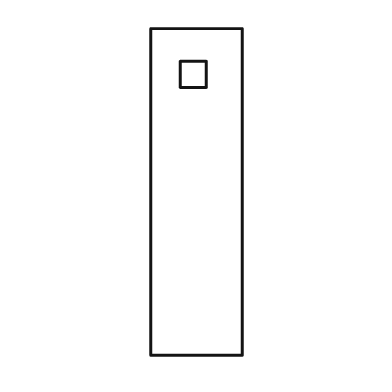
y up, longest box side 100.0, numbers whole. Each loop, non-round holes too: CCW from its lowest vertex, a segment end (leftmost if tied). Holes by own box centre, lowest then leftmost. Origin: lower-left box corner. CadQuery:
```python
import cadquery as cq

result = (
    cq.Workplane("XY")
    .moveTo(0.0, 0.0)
    .lineTo(28.0, 0.0)
    .lineTo(28.0, 100.0)
    .lineTo(0.0, 100.0)
    .close()
    .moveTo(9.0, 82.0)
    .lineTo(17.0, 82.0)
    .lineTo(17.0, 90.0)
    .lineTo(9.0, 90.0)
    .close()
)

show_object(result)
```